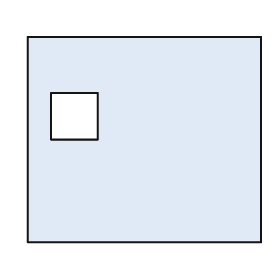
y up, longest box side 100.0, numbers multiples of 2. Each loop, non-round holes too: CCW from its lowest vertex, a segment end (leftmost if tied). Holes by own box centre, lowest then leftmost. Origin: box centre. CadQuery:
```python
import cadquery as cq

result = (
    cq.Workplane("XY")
    .moveTo(-50.0, -44.0)
    .lineTo(50.0, -44.0)
    .lineTo(50.0, 44.0)
    .lineTo(-50.0, 44.0)
    .close()
    .moveTo(-40.0, 0.0)
    .lineTo(-20.0, 0.0)
    .lineTo(-20.0, 20.0)
    .lineTo(-40.0, 20.0)
    .close()
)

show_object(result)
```